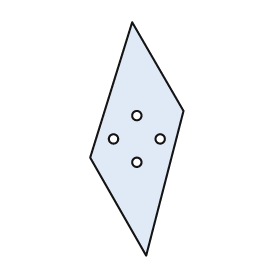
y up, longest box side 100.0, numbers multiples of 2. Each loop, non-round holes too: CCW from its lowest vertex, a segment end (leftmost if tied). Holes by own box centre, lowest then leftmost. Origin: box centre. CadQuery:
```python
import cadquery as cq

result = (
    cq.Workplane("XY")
    .moveTo(4.0, -50.0)
    .lineTo(20.0, 12.0)
    .lineTo(-2.0, 50.0)
    .lineTo(-20.0, -8.0)
    .close()
    .moveTo(0.0, -10.0)
    .circle(2.0)
    .moveTo(-10.0, 0.0)
    .circle(2.0)
    .moveTo(10.0, 0.0)
    .circle(2.0)
    .moveTo(0.0, 10.0)
    .circle(2.0)
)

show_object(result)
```